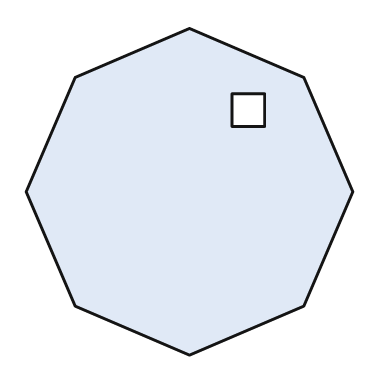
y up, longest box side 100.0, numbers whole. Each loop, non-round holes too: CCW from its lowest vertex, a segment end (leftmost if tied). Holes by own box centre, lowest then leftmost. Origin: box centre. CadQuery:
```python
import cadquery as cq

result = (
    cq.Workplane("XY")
    .moveTo(0.0, -50.0)
    .lineTo(35.0, -35.0)
    .lineTo(50.0, 0.0)
    .lineTo(35.0, 35.0)
    .lineTo(0.0, 50.0)
    .lineTo(-35.0, 35.0)
    .lineTo(-50.0, 0.0)
    .lineTo(-35.0, -35.0)
    .close()
    .moveTo(13.0, 20.0)
    .lineTo(23.0, 20.0)
    .lineTo(23.0, 30.0)
    .lineTo(13.0, 30.0)
    .close()
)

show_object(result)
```